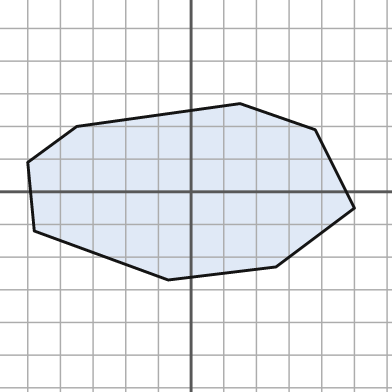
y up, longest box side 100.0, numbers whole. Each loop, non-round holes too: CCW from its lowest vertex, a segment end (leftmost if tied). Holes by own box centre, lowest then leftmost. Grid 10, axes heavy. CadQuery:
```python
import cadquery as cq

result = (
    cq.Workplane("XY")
    .moveTo(-7.0, -27.0)
    .lineTo(26.0, -23.0)
    .lineTo(50.0, -5.0)
    .lineTo(38.0, 19.0)
    .lineTo(15.0, 27.0)
    .lineTo(-35.0, 20.0)
    .lineTo(-50.0, 9.0)
    .lineTo(-48.0, -12.0)
    .close()
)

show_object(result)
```